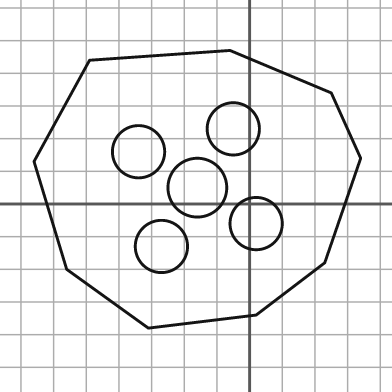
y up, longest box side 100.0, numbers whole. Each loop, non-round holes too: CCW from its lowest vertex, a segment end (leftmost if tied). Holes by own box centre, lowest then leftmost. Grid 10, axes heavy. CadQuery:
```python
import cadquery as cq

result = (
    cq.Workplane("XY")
    .moveTo(-31.0, -38.0)
    .lineTo(2.0, -34.0)
    .lineTo(23.0, -18.0)
    .lineTo(34.0, 14.0)
    .lineTo(25.0, 34.0)
    .lineTo(-6.0, 47.0)
    .lineTo(-49.0, 44.0)
    .lineTo(-66.0, 13.0)
    .lineTo(-56.0, -20.0)
    .close()
    .moveTo(-27.0, -13.0)
    .circle(8.0)
    .moveTo(2.0, -6.0)
    .circle(8.0)
    .moveTo(-16.0, 5.0)
    .circle(9.0)
    .moveTo(-34.0, 16.0)
    .circle(8.0)
    .moveTo(-5.0, 23.0)
    .circle(8.0)
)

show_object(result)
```